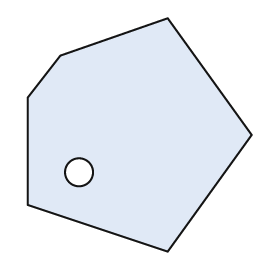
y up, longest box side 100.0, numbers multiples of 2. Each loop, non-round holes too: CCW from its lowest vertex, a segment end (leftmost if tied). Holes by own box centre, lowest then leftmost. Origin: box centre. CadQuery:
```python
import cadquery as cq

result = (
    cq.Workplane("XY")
    .moveTo(12.0, -50.0)
    .lineTo(48.0, 0.0)
    .lineTo(12.0, 50.0)
    .lineTo(-34.0, 34.0)
    .lineTo(-48.0, 16.0)
    .lineTo(-48.0, -30.0)
    .close()
    .moveTo(-26.0, -16.0)
    .circle(6.0)
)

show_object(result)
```